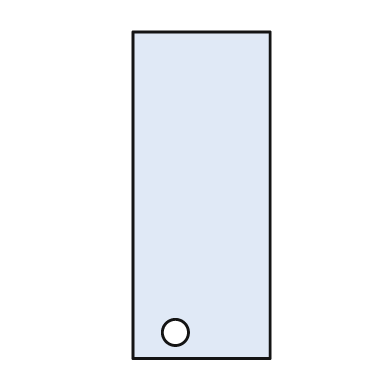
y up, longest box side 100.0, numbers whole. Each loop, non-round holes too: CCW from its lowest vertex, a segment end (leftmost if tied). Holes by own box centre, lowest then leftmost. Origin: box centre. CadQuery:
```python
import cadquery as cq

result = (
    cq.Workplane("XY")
    .moveTo(-21.0, -50.0)
    .lineTo(21.0, -50.0)
    .lineTo(21.0, 50.0)
    .lineTo(-21.0, 50.0)
    .close()
    .moveTo(-8.0, -42.0)
    .circle(4.0)
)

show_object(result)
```